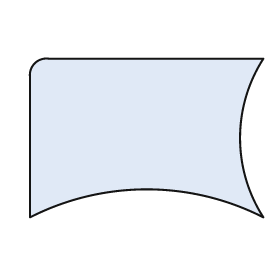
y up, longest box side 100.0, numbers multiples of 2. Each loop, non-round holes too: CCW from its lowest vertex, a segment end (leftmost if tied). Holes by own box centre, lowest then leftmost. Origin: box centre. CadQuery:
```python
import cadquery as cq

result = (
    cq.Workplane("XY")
    .moveTo(-50.0, -34.0)
    .threePointArc((0.0, -22.0), (50.0, -34.0))
    .threePointArc((40.0, 0.0), (50.0, 34.0))
    .lineTo(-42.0, 34.0)
    .threePointArc((-48.0, 32.0), (-50.0, 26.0))
    .close()
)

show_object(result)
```